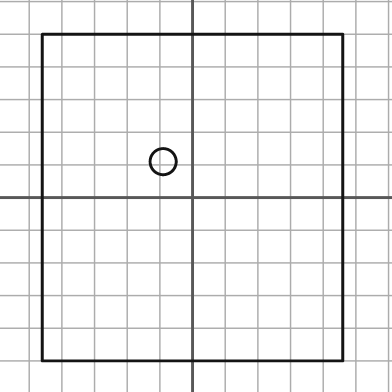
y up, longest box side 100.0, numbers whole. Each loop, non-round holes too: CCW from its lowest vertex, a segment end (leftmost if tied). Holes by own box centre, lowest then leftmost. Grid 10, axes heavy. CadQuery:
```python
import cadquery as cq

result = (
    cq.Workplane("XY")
    .moveTo(-46.0, -50.0)
    .lineTo(46.0, -50.0)
    .lineTo(46.0, 50.0)
    .lineTo(-46.0, 50.0)
    .close()
    .moveTo(-9.0, 11.0)
    .circle(4.0)
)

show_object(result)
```